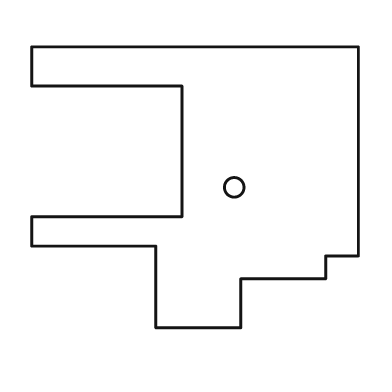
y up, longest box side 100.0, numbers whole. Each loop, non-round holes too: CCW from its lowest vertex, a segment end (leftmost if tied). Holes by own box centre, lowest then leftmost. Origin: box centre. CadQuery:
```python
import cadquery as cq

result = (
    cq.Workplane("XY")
    .moveTo(-12.0, -43.0)
    .lineTo(14.0, -43.0)
    .lineTo(14.0, -28.0)
    .lineTo(40.0, -28.0)
    .lineTo(40.0, -21.0)
    .lineTo(50.0, -21.0)
    .lineTo(50.0, 43.0)
    .lineTo(-50.0, 43.0)
    .lineTo(-50.0, 31.0)
    .lineTo(-4.0, 31.0)
    .lineTo(-4.0, -9.0)
    .lineTo(-50.0, -9.0)
    .lineTo(-50.0, -18.0)
    .lineTo(-12.0, -18.0)
    .close()
    .moveTo(12.0, 0.0)
    .circle(3.0)
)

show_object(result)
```